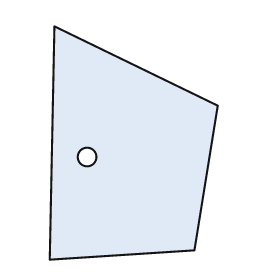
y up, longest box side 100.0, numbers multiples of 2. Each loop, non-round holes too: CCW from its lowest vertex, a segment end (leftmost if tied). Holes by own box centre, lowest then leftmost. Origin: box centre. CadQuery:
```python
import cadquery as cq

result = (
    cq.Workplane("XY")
    .moveTo(-36.0, -50.0)
    .lineTo(26.0, -46.0)
    .lineTo(36.0, 16.0)
    .lineTo(-34.0, 50.0)
    .close()
    .moveTo(-20.0, -6.0)
    .circle(4.0)
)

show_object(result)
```